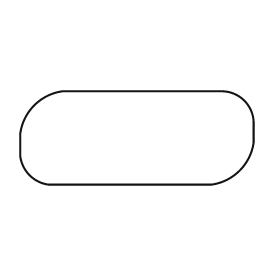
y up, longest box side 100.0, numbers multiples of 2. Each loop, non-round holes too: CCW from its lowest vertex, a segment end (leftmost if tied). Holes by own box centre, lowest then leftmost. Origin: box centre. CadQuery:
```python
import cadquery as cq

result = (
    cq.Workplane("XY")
    .moveTo(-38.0, -20.0)
    .lineTo(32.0, -20.0)
    .threePointArc((44.0, -14.0), (50.0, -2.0))
    .lineTo(50.0, 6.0)
    .threePointArc((46.0, 16.0), (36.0, 20.0))
    .lineTo(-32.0, 20.0)
    .threePointArc((-44.0, 14.0), (-50.0, 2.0))
    .lineTo(-50.0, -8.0)
    .threePointArc((-46.0, -16.0), (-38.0, -20.0))
    .close()
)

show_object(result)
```